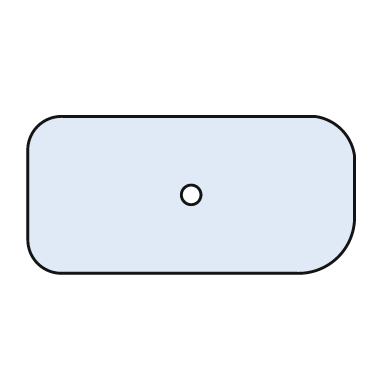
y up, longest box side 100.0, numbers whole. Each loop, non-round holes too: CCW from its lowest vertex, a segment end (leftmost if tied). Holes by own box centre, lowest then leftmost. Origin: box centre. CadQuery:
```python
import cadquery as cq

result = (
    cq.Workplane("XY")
    .moveTo(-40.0, -24.0)
    .lineTo(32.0, -24.0)
    .threePointArc((45.0, -19.0), (50.0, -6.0))
    .lineTo(50.0, 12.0)
    .threePointArc((46.0, 20.0), (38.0, 24.0))
    .lineTo(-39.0, 24.0)
    .threePointArc((-47.0, 21.0), (-50.0, 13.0))
    .lineTo(-50.0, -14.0)
    .threePointArc((-47.0, -21.0), (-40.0, -24.0))
    .close()
    .moveTo(0.0, 0.0)
    .circle(3.0)
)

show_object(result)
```